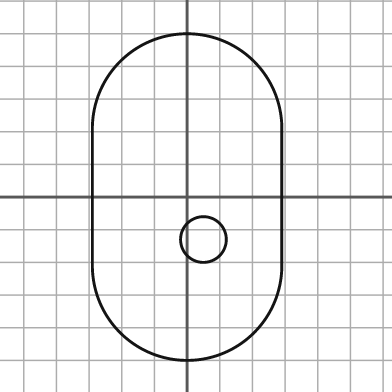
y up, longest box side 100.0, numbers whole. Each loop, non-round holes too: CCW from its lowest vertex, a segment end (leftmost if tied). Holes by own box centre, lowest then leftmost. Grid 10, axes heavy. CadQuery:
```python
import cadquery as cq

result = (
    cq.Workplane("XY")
    .moveTo(-29.0, -21.0)
    .threePointArc((0.0, -50.0), (29.0, -21.0))
    .lineTo(29.0, 21.0)
    .threePointArc((0.0, 50.0), (-29.0, 21.0))
    .close()
    .moveTo(5.0, -13.0)
    .circle(7.0)
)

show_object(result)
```